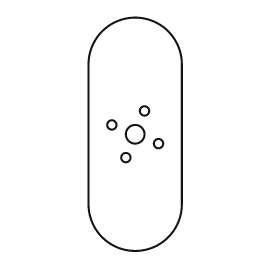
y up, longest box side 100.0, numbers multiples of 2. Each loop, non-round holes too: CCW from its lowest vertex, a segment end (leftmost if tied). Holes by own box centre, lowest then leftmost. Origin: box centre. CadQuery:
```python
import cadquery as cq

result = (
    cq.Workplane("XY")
    .moveTo(-20.0, -30.0)
    .threePointArc((0.0, -50.0), (20.0, -30.0))
    .lineTo(20.0, 30.0)
    .threePointArc((0.0, 50.0), (-20.0, 30.0))
    .close()
    .moveTo(-4.0, -10.0)
    .circle(2.0)
    .moveTo(10.0, -4.0)
    .circle(2.0)
    .moveTo(0.0, 0.0)
    .circle(4.0)
    .moveTo(-10.0, 4.0)
    .circle(2.0)
    .moveTo(4.0, 10.0)
    .circle(2.0)
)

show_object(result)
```